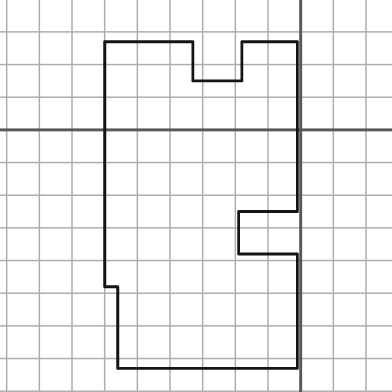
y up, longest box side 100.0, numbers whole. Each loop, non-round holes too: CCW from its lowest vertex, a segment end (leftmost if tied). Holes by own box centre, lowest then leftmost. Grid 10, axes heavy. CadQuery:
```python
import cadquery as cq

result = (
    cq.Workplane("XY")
    .moveTo(-56.0, -73.0)
    .lineTo(-1.0, -73.0)
    .lineTo(-1.0, -38.0)
    .lineTo(-19.0, -38.0)
    .lineTo(-19.0, -25.0)
    .lineTo(-1.0, -25.0)
    .lineTo(-1.0, 27.0)
    .lineTo(-18.0, 27.0)
    .lineTo(-18.0, 15.0)
    .lineTo(-33.0, 15.0)
    .lineTo(-33.0, 27.0)
    .lineTo(-60.0, 27.0)
    .lineTo(-60.0, -48.0)
    .lineTo(-56.0, -48.0)
    .close()
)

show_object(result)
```